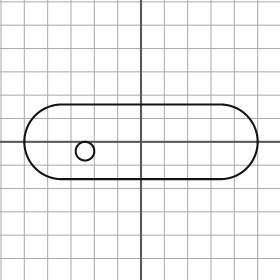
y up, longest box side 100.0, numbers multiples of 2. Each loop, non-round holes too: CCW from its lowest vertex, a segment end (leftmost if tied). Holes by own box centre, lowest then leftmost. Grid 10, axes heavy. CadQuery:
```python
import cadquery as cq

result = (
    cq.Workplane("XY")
    .moveTo(-34.0, -16.0)
    .lineTo(34.0, -16.0)
    .threePointArc((50.0, 0.0), (34.0, 16.0))
    .lineTo(-34.0, 16.0)
    .threePointArc((-50.0, 0.0), (-34.0, -16.0))
    .close()
    .moveTo(-24.0, -4.0)
    .circle(4.0)
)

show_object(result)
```